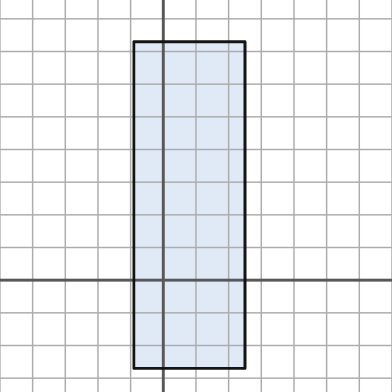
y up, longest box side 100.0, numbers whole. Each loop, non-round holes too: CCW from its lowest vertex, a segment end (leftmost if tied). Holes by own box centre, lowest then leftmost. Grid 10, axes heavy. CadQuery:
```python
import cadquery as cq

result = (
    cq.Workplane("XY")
    .moveTo(-9.0, -27.0)
    .lineTo(25.0, -27.0)
    .lineTo(25.0, 73.0)
    .lineTo(-9.0, 73.0)
    .close()
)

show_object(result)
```